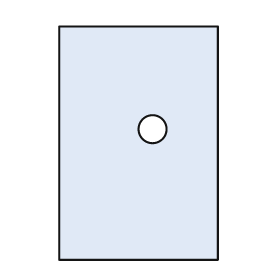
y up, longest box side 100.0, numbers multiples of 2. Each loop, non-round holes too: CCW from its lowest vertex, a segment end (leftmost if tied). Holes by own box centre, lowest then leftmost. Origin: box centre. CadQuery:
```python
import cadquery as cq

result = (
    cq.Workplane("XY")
    .moveTo(-34.0, -50.0)
    .lineTo(34.0, -50.0)
    .lineTo(34.0, 50.0)
    .lineTo(-34.0, 50.0)
    .close()
    .moveTo(6.0, 6.0)
    .circle(6.0)
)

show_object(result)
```